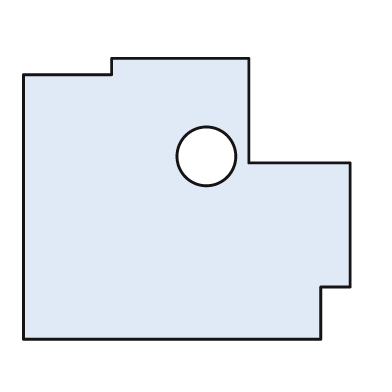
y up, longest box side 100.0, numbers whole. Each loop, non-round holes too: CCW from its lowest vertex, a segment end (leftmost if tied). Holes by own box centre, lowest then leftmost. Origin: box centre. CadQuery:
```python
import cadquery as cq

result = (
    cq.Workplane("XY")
    .moveTo(-50.0, -43.0)
    .lineTo(41.0, -43.0)
    .lineTo(41.0, -27.0)
    .lineTo(50.0, -27.0)
    .lineTo(50.0, 11.0)
    .lineTo(19.0, 11.0)
    .lineTo(19.0, 43.0)
    .lineTo(-23.0, 43.0)
    .lineTo(-23.0, 38.0)
    .lineTo(-50.0, 38.0)
    .close()
    .moveTo(6.0, 13.0)
    .circle(9.0)
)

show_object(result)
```